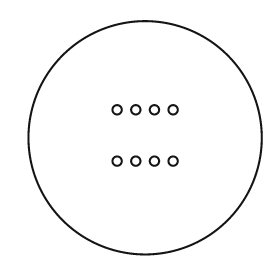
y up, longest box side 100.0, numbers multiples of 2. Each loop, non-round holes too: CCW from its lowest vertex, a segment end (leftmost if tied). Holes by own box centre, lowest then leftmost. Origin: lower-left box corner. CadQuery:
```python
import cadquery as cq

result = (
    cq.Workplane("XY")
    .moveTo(50.0, 50.0)
    .circle(50.0)
    .moveTo(38.0, 40.0)
    .circle(2.0)
    .moveTo(46.0, 40.0)
    .circle(2.0)
    .moveTo(54.0, 40.0)
    .circle(2.0)
    .moveTo(62.0, 40.0)
    .circle(2.0)
    .moveTo(38.0, 62.0)
    .circle(2.0)
    .moveTo(46.0, 62.0)
    .circle(2.0)
    .moveTo(54.0, 62.0)
    .circle(2.0)
    .moveTo(62.0, 62.0)
    .circle(2.0)
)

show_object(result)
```